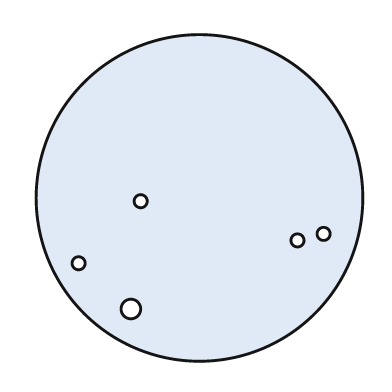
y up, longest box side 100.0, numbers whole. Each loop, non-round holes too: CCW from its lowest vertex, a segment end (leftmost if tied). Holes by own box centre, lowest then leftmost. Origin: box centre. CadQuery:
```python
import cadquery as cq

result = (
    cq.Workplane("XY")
    .moveTo(0.0, 0.0)
    .circle(50.0)
    .moveTo(-21.0, -34.0)
    .circle(3.0)
    .moveTo(-37.0, -20.0)
    .circle(2.0)
    .moveTo(30.0, -13.0)
    .circle(2.0)
    .moveTo(38.0, -11.0)
    .circle(2.0)
    .moveTo(-18.0, -1.0)
    .circle(2.0)
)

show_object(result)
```